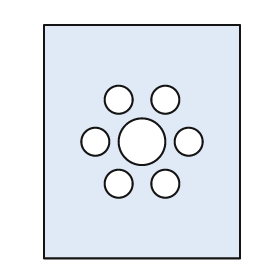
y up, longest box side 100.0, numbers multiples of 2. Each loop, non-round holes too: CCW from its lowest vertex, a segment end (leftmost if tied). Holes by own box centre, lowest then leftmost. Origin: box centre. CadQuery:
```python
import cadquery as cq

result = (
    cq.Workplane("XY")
    .moveTo(-42.0, -50.0)
    .lineTo(42.0, -50.0)
    .lineTo(42.0, 50.0)
    .lineTo(-42.0, 50.0)
    .close()
    .moveTo(-10.0, -18.0)
    .circle(6.0)
    .moveTo(10.0, -18.0)
    .circle(6.0)
    .moveTo(-20.0, 0.0)
    .circle(6.0)
    .moveTo(0.0, 0.0)
    .circle(10.0)
    .moveTo(20.0, 0.0)
    .circle(6.0)
    .moveTo(-10.0, 18.0)
    .circle(6.0)
    .moveTo(10.0, 18.0)
    .circle(6.0)
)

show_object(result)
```